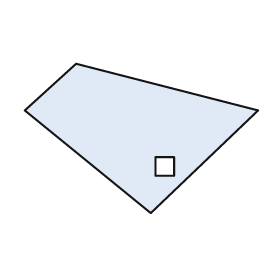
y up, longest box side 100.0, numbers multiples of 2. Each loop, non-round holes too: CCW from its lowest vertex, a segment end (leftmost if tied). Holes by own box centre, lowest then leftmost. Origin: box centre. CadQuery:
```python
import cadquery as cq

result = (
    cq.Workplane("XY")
    .moveTo(4.0, -32.0)
    .lineTo(50.0, 12.0)
    .lineTo(-28.0, 32.0)
    .lineTo(-50.0, 12.0)
    .close()
    .moveTo(6.0, -16.0)
    .lineTo(14.0, -16.0)
    .lineTo(14.0, -8.0)
    .lineTo(6.0, -8.0)
    .close()
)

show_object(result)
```